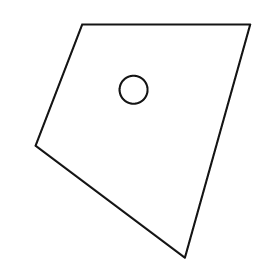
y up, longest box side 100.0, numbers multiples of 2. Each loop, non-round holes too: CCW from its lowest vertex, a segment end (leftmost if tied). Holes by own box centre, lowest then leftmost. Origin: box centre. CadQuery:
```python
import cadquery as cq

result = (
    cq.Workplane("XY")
    .moveTo(18.0, -50.0)
    .lineTo(46.0, 50.0)
    .lineTo(-26.0, 50.0)
    .lineTo(-46.0, -2.0)
    .close()
    .moveTo(-4.0, 22.0)
    .circle(6.0)
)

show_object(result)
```